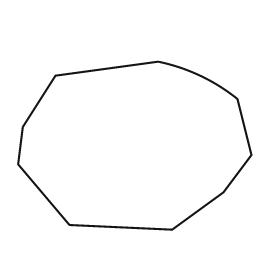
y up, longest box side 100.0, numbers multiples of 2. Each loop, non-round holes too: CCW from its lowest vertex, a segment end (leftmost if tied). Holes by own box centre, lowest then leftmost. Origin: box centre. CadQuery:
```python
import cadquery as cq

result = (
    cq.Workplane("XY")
    .moveTo(16.0, -36.0)
    .lineTo(38.0, -20.0)
    .lineTo(50.0, -4.0)
    .lineTo(44.0, 20.0)
    .threePointArc((28.0, 30.0), (10.0, 36.0))
    .lineTo(-34.0, 30.0)
    .lineTo(-48.0, 8.0)
    .lineTo(-50.0, -8.0)
    .lineTo(-28.0, -34.0)
    .close()
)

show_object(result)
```